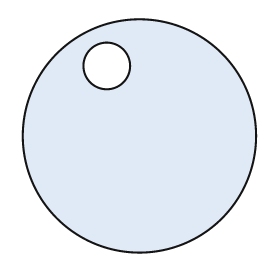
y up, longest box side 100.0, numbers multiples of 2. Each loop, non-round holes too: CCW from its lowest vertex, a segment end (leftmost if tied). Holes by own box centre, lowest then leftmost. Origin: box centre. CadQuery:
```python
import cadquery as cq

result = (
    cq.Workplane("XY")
    .moveTo(0.0, 0.0)
    .circle(50.0)
    .moveTo(-14.0, 30.0)
    .circle(10.0)
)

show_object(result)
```